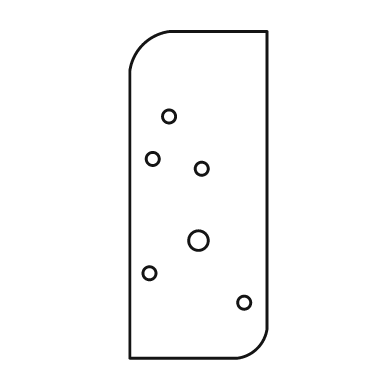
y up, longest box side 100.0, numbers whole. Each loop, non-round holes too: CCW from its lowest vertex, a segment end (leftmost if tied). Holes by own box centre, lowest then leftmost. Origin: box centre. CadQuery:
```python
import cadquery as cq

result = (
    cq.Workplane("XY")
    .moveTo(-21.0, -50.0)
    .lineTo(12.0, -50.0)
    .threePointArc((18.0, -47.0), (21.0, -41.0))
    .lineTo(21.0, 50.0)
    .lineTo(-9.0, 50.0)
    .threePointArc((-17.0, 46.0), (-21.0, 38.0))
    .close()
    .moveTo(14.0, -33.0)
    .circle(2.0)
    .moveTo(-15.0, -24.0)
    .circle(2.0)
    .moveTo(0.0, -14.0)
    .circle(3.0)
    .moveTo(1.0, 8.0)
    .circle(2.0)
    .moveTo(-14.0, 11.0)
    .circle(2.0)
    .moveTo(-9.0, 24.0)
    .circle(2.0)
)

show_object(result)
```